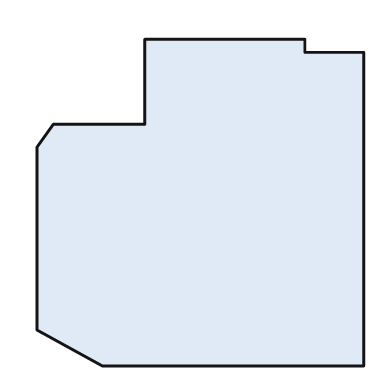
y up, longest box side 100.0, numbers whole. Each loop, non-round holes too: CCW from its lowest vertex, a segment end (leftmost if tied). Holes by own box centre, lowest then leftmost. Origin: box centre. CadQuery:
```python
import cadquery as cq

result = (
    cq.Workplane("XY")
    .moveTo(-30.0, -50.0)
    .lineTo(50.0, -50.0)
    .lineTo(50.0, 46.0)
    .lineTo(32.0, 46.0)
    .lineTo(32.0, 50.0)
    .lineTo(-17.0, 50.0)
    .lineTo(-17.0, 24.0)
    .lineTo(-45.0, 24.0)
    .lineTo(-50.0, 17.0)
    .lineTo(-50.0, -39.0)
    .close()
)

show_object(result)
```